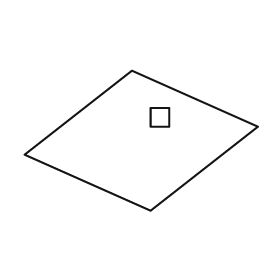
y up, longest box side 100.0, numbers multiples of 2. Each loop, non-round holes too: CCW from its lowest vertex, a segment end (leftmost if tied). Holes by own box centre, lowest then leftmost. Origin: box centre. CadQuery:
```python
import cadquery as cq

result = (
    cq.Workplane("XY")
    .moveTo(4.0, -30.0)
    .lineTo(50.0, 6.0)
    .lineTo(-4.0, 30.0)
    .lineTo(-50.0, -6.0)
    .close()
    .moveTo(4.0, 6.0)
    .lineTo(12.0, 6.0)
    .lineTo(12.0, 14.0)
    .lineTo(4.0, 14.0)
    .close()
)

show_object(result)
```